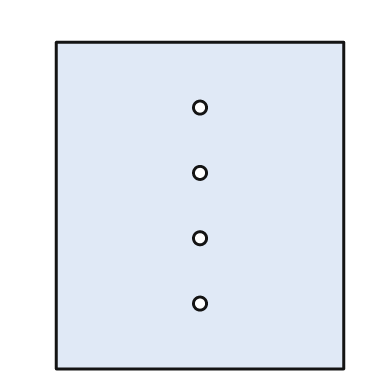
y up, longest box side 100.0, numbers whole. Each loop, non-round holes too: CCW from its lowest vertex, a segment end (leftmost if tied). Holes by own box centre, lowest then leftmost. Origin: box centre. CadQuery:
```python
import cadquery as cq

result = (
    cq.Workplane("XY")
    .moveTo(-44.0, -50.0)
    .lineTo(44.0, -50.0)
    .lineTo(44.0, 50.0)
    .lineTo(-44.0, 50.0)
    .close()
    .moveTo(0.0, -30.0)
    .circle(2.0)
    .moveTo(0.0, -10.0)
    .circle(2.0)
    .moveTo(0.0, 10.0)
    .circle(2.0)
    .moveTo(0.0, 30.0)
    .circle(2.0)
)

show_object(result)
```